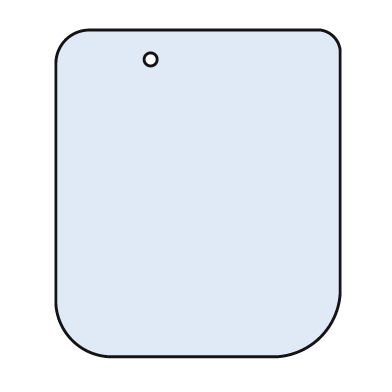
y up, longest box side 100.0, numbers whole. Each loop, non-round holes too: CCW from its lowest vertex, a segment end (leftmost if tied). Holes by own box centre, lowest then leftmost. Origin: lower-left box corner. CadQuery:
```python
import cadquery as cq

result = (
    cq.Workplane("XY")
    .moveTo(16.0, 0.0)
    .lineTo(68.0, 0.0)
    .threePointArc((81.0, 6.0), (87.0, 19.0))
    .lineTo(87.0, 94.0)
    .threePointArc((85.0, 98.0), (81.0, 100.0))
    .lineTo(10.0, 100.0)
    .threePointArc((3.0, 97.0), (0.0, 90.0))
    .lineTo(0.0, 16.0)
    .threePointArc((5.0, 5.0), (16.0, 0.0))
    .close()
    .moveTo(29.0, 91.0)
    .circle(2.0)
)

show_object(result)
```